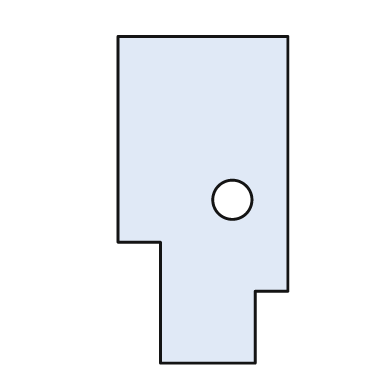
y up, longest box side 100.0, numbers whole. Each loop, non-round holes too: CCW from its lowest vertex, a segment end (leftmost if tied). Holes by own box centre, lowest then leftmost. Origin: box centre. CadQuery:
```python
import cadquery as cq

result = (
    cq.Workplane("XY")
    .moveTo(-13.0, -50.0)
    .lineTo(16.0, -50.0)
    .lineTo(16.0, -28.0)
    .lineTo(26.0, -28.0)
    .lineTo(26.0, 50.0)
    .lineTo(-26.0, 50.0)
    .lineTo(-26.0, -13.0)
    .lineTo(-13.0, -13.0)
    .close()
    .moveTo(9.0, 0.0)
    .circle(6.0)
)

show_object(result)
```